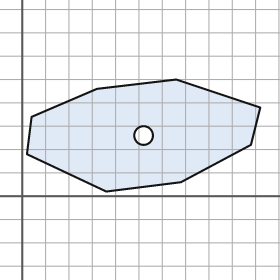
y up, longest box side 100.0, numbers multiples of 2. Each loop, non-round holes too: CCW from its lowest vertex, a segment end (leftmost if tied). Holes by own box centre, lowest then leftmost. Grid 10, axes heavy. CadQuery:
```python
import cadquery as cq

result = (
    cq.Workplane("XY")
    .moveTo(36.0, 2.0)
    .lineTo(68.0, 6.0)
    .lineTo(98.0, 22.0)
    .lineTo(102.0, 38.0)
    .lineTo(66.0, 50.0)
    .lineTo(32.0, 46.0)
    .lineTo(4.0, 34.0)
    .lineTo(2.0, 18.0)
    .close()
    .moveTo(52.0, 26.0)
    .circle(4.0)
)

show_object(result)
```